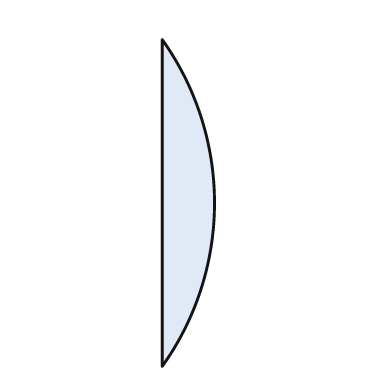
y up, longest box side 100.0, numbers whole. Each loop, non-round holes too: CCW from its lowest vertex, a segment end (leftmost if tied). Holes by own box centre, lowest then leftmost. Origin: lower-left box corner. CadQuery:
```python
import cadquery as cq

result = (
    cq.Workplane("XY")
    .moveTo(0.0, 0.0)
    .threePointArc((16.0, 50.0), (0.0, 100.0))
    .close()
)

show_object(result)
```